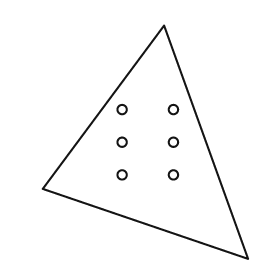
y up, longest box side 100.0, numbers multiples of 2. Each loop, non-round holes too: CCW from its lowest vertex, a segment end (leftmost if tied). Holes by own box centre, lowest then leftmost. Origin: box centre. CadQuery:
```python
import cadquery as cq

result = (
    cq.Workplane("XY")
    .moveTo(44.0, -50.0)
    .lineTo(8.0, 50.0)
    .lineTo(-44.0, -20.0)
    .close()
    .moveTo(-10.0, -14.0)
    .circle(2.0)
    .moveTo(12.0, -14.0)
    .circle(2.0)
    .moveTo(-10.0, 0.0)
    .circle(2.0)
    .moveTo(12.0, 0.0)
    .circle(2.0)
    .moveTo(-10.0, 14.0)
    .circle(2.0)
    .moveTo(12.0, 14.0)
    .circle(2.0)
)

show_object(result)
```